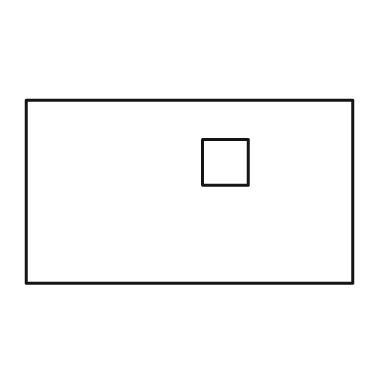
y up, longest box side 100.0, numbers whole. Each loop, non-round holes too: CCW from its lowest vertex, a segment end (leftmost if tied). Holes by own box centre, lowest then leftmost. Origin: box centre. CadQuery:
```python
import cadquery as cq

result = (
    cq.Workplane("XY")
    .moveTo(-50.0, -28.0)
    .lineTo(50.0, -28.0)
    .lineTo(50.0, 28.0)
    .lineTo(-50.0, 28.0)
    .close()
    .moveTo(4.0, 2.0)
    .lineTo(18.0, 2.0)
    .lineTo(18.0, 16.0)
    .lineTo(4.0, 16.0)
    .close()
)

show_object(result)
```